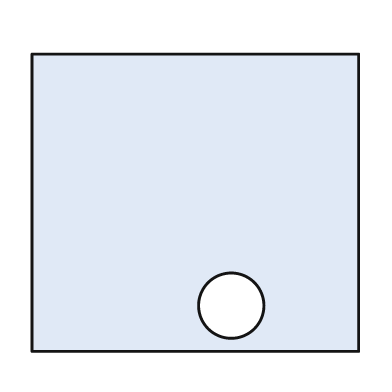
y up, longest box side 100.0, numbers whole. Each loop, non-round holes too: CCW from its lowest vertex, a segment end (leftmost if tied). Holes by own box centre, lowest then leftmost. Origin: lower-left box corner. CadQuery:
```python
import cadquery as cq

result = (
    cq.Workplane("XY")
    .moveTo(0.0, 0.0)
    .lineTo(100.0, 0.0)
    .lineTo(100.0, 91.0)
    .lineTo(0.0, 91.0)
    .close()
    .moveTo(61.0, 14.0)
    .circle(10.0)
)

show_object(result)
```